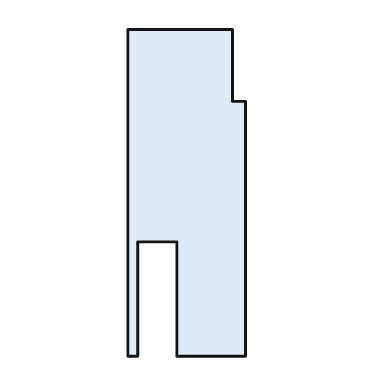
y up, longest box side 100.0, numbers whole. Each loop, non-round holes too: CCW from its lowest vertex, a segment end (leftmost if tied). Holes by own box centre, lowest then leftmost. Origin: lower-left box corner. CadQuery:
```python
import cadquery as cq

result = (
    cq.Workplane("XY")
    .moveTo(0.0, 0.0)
    .lineTo(3.0, 0.0)
    .lineTo(3.0, 35.0)
    .lineTo(15.0, 35.0)
    .lineTo(15.0, 0.0)
    .lineTo(36.0, 0.0)
    .lineTo(36.0, 78.0)
    .lineTo(32.0, 78.0)
    .lineTo(32.0, 100.0)
    .lineTo(0.0, 100.0)
    .close()
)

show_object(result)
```